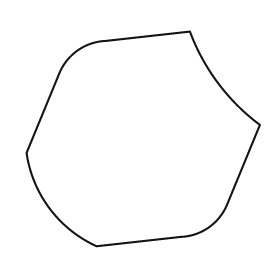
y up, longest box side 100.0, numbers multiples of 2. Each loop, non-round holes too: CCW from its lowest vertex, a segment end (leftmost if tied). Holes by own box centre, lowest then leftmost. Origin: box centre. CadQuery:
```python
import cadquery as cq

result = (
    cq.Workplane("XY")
    .moveTo(-20.0, -46.0)
    .lineTo(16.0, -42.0)
    .threePointArc((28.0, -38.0), (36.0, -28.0))
    .lineTo(50.0, 6.0)
    .threePointArc((32.0, 24.0), (20.0, 46.0))
    .lineTo(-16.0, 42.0)
    .threePointArc((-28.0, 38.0), (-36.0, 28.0))
    .lineTo(-50.0, -6.0)
    .threePointArc((-40.0, -30.0), (-20.0, -46.0))
    .close()
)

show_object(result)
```